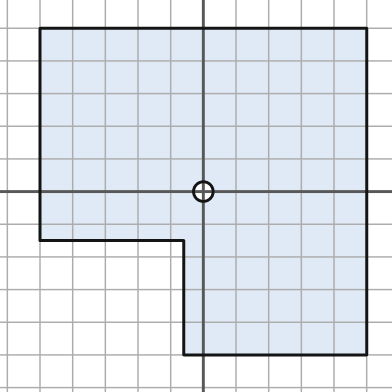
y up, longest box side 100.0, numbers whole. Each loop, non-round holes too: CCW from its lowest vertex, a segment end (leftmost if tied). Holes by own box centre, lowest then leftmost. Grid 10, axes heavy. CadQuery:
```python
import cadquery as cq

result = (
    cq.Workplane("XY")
    .moveTo(-6.0, -50.0)
    .lineTo(50.0, -50.0)
    .lineTo(50.0, 50.0)
    .lineTo(-50.0, 50.0)
    .lineTo(-50.0, -15.0)
    .lineTo(-6.0, -15.0)
    .close()
    .moveTo(0.0, 0.0)
    .circle(3.0)
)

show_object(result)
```